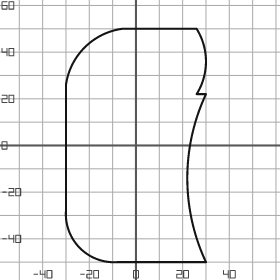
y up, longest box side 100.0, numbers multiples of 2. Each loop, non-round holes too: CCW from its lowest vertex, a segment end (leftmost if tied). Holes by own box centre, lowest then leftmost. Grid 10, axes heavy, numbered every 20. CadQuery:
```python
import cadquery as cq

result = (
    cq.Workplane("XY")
    .moveTo(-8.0, -50.0)
    .lineTo(30.0, -50.0)
    .threePointArc((22.0, -14.0), (30.0, 22.0))
    .lineTo(26.0, 22.0)
    .threePointArc((30.0, 36.0), (26.0, 50.0))
    .lineTo(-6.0, 50.0)
    .threePointArc((-22.0, 42.0), (-30.0, 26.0))
    .lineTo(-30.0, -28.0)
    .threePointArc((-24.0, -44.0), (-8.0, -50.0))
    .close()
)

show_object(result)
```